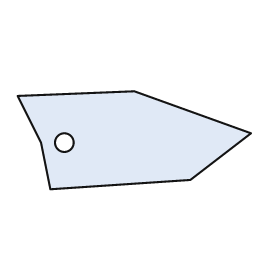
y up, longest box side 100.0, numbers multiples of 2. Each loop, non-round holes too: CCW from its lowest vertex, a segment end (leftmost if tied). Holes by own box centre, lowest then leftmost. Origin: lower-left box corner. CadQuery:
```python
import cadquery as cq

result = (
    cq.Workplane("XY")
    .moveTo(14.0, 0.0)
    .lineTo(74.0, 4.0)
    .lineTo(100.0, 24.0)
    .lineTo(50.0, 42.0)
    .lineTo(0.0, 40.0)
    .lineTo(10.0, 20.0)
    .close()
    .moveTo(20.0, 20.0)
    .circle(4.0)
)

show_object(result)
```